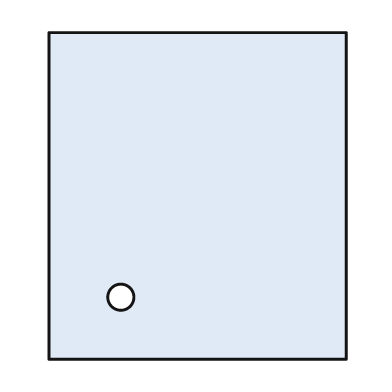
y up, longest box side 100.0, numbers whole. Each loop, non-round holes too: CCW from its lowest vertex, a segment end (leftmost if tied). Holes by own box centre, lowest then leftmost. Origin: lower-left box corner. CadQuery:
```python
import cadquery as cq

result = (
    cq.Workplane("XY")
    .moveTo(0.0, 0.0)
    .lineTo(91.0, 0.0)
    .lineTo(91.0, 100.0)
    .lineTo(0.0, 100.0)
    .close()
    .moveTo(22.0, 19.0)
    .circle(4.0)
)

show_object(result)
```